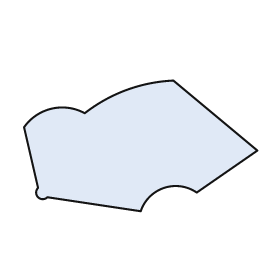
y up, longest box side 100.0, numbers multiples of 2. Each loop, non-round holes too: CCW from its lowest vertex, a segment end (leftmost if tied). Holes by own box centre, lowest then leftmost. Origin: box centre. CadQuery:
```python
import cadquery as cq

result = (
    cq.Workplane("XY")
    .moveTo(0.0, -28.0)
    .threePointArc((10.0, -18.0), (24.0, -20.0))
    .lineTo(50.0, -2.0)
    .lineTo(14.0, 28.0)
    .threePointArc((-6.0, 24.0), (-24.0, 14.0))
    .threePointArc((-38.0, 16.0), (-50.0, 8.0))
    .lineTo(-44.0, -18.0)
    .threePointArc((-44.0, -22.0), (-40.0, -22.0))
    .close()
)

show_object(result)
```